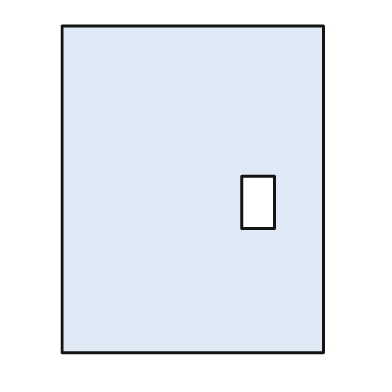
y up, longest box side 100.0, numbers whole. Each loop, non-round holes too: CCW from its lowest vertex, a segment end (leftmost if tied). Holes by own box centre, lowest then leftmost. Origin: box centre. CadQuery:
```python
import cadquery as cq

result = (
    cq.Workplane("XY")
    .moveTo(-40.0, -50.0)
    .lineTo(40.0, -50.0)
    .lineTo(40.0, 50.0)
    .lineTo(-40.0, 50.0)
    .close()
    .moveTo(15.0, -12.0)
    .lineTo(25.0, -12.0)
    .lineTo(25.0, 4.0)
    .lineTo(15.0, 4.0)
    .close()
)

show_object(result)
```